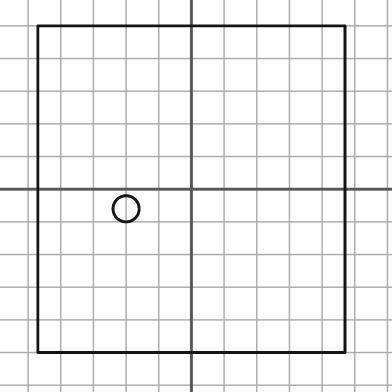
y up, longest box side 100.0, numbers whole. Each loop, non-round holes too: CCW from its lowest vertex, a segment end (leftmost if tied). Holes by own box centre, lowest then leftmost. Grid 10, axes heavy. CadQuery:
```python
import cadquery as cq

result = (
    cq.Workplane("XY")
    .moveTo(-47.0, -50.0)
    .lineTo(47.0, -50.0)
    .lineTo(47.0, 50.0)
    .lineTo(-47.0, 50.0)
    .close()
    .moveTo(-20.0, -6.0)
    .circle(4.0)
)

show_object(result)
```